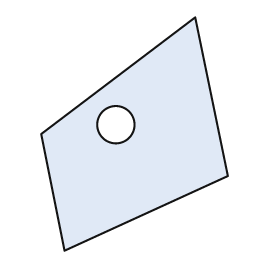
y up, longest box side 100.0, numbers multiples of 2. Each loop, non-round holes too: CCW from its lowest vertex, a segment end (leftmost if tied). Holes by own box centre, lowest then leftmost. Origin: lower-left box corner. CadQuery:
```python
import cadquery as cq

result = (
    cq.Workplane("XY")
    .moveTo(10.0, 0.0)
    .lineTo(80.0, 32.0)
    .lineTo(66.0, 100.0)
    .lineTo(0.0, 50.0)
    .close()
    .moveTo(32.0, 54.0)
    .circle(8.0)
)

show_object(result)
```